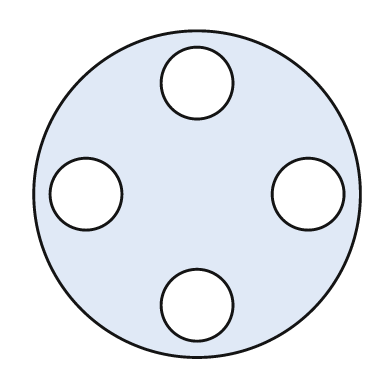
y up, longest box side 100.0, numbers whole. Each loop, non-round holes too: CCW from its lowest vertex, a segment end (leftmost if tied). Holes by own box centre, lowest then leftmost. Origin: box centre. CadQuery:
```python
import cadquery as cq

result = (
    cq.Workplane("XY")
    .moveTo(0.0, 0.0)
    .circle(50.0)
    .moveTo(0.0, -34.0)
    .circle(11.0)
    .moveTo(-34.0, 0.0)
    .circle(11.0)
    .moveTo(34.0, 0.0)
    .circle(11.0)
    .moveTo(0.0, 34.0)
    .circle(11.0)
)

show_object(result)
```